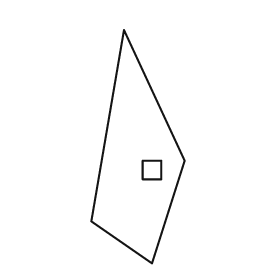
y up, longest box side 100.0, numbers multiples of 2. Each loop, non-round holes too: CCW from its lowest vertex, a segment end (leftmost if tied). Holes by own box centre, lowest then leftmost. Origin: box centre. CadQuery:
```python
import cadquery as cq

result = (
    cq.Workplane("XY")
    .moveTo(6.0, -50.0)
    .lineTo(20.0, -6.0)
    .lineTo(-6.0, 50.0)
    .lineTo(-20.0, -32.0)
    .close()
    .moveTo(2.0, -14.0)
    .lineTo(10.0, -14.0)
    .lineTo(10.0, -6.0)
    .lineTo(2.0, -6.0)
    .close()
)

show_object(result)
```